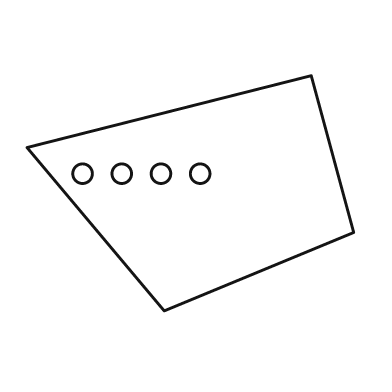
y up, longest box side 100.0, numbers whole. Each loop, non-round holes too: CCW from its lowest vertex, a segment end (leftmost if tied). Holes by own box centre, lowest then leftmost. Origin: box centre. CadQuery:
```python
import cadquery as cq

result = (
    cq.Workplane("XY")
    .moveTo(-8.0, -36.0)
    .lineTo(50.0, -12.0)
    .lineTo(37.0, 36.0)
    .lineTo(-50.0, 14.0)
    .close()
    .moveTo(-33.0, 6.0)
    .circle(3.0)
    .moveTo(-21.0, 6.0)
    .circle(3.0)
    .moveTo(-9.0, 6.0)
    .circle(3.0)
    .moveTo(3.0, 6.0)
    .circle(3.0)
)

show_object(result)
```